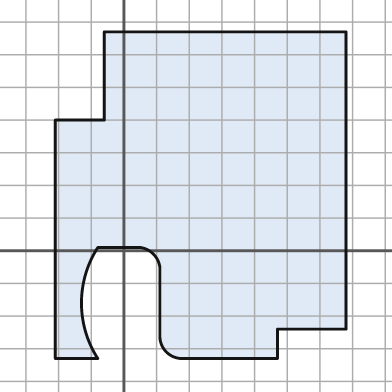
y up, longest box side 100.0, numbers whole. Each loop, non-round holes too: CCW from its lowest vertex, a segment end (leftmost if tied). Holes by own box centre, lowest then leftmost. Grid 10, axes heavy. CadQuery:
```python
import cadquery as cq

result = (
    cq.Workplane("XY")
    .moveTo(-21.0, -33.0)
    .lineTo(-8.0, -33.0)
    .threePointArc((-13.0, -16.0), (-8.0, 1.0))
    .lineTo(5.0, 1.0)
    .threePointArc((9.0, -1.0), (11.0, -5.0))
    .lineTo(11.0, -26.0)
    .threePointArc((13.0, -31.0), (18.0, -33.0))
    .lineTo(47.0, -33.0)
    .lineTo(47.0, -24.0)
    .lineTo(68.0, -24.0)
    .lineTo(68.0, 67.0)
    .lineTo(-6.0, 67.0)
    .lineTo(-6.0, 40.0)
    .lineTo(-21.0, 40.0)
    .close()
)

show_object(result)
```